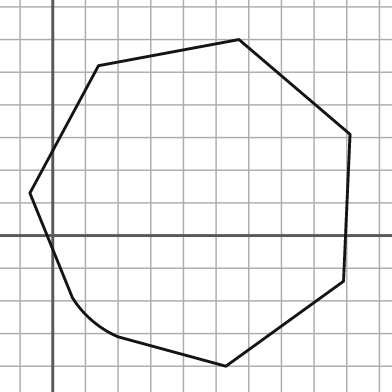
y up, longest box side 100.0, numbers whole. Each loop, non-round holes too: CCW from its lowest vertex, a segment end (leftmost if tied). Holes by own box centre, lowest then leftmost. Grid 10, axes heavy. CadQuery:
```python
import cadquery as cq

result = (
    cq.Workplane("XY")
    .moveTo(53.0, -40.0)
    .lineTo(89.0, -14.0)
    .lineTo(91.0, 31.0)
    .lineTo(57.0, 60.0)
    .lineTo(14.0, 52.0)
    .lineTo(-7.0, 13.0)
    .lineTo(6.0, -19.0)
    .threePointArc((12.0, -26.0), (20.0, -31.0))
    .close()
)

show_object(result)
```